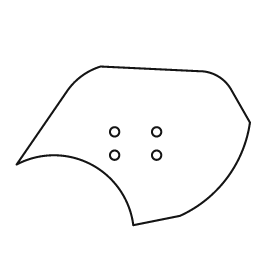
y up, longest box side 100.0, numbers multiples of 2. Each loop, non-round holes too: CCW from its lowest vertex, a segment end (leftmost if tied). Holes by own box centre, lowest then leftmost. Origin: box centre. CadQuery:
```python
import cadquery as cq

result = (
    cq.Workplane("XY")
    .moveTo(0.0, -34.0)
    .lineTo(20.0, -30.0)
    .threePointArc((40.0, -14.0), (50.0, 10.0))
    .lineTo(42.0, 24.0)
    .threePointArc((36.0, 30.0), (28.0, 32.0))
    .lineTo(-14.0, 34.0)
    .threePointArc((-22.0, 30.0), (-28.0, 24.0))
    .lineTo(-50.0, -8.0)
    .threePointArc((-18.0, -8.0), (0.0, -34.0))
    .close()
    .moveTo(-8.0, -4.0)
    .circle(2.0)
    .moveTo(10.0, -4.0)
    .circle(2.0)
    .moveTo(-8.0, 6.0)
    .circle(2.0)
    .moveTo(10.0, 6.0)
    .circle(2.0)
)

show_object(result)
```